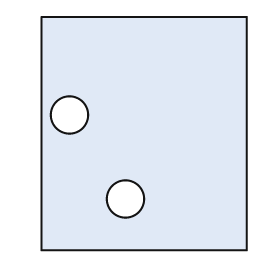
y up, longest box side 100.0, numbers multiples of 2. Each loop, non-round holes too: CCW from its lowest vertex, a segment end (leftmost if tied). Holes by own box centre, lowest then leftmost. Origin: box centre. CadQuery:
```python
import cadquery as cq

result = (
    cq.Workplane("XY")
    .moveTo(-44.0, -50.0)
    .lineTo(44.0, -50.0)
    .lineTo(44.0, 50.0)
    .lineTo(-44.0, 50.0)
    .close()
    .moveTo(-8.0, -28.0)
    .circle(8.0)
    .moveTo(-32.0, 8.0)
    .circle(8.0)
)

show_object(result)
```